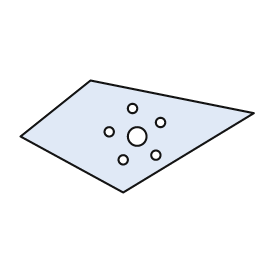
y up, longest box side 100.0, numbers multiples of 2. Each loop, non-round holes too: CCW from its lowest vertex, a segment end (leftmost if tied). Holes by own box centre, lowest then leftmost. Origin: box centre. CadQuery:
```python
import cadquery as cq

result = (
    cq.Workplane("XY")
    .moveTo(-6.0, -24.0)
    .lineTo(50.0, 10.0)
    .lineTo(-20.0, 24.0)
    .lineTo(-50.0, 0.0)
    .close()
    .moveTo(-6.0, -10.0)
    .circle(2.0)
    .moveTo(8.0, -8.0)
    .circle(2.0)
    .moveTo(0.0, 0.0)
    .circle(4.0)
    .moveTo(-12.0, 2.0)
    .circle(2.0)
    .moveTo(10.0, 6.0)
    .circle(2.0)
    .moveTo(-2.0, 12.0)
    .circle(2.0)
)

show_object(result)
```